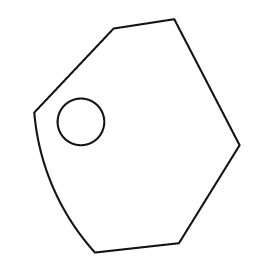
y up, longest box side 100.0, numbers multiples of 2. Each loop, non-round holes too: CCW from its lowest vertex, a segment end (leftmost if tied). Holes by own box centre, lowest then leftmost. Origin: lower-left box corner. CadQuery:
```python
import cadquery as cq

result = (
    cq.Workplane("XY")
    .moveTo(26.0, 0.0)
    .lineTo(62.0, 4.0)
    .lineTo(88.0, 46.0)
    .lineTo(60.0, 100.0)
    .lineTo(34.0, 96.0)
    .lineTo(0.0, 60.0)
    .threePointArc((8.0, 28.0), (26.0, 0.0))
    .close()
    .moveTo(20.0, 56.0)
    .circle(10.0)
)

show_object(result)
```